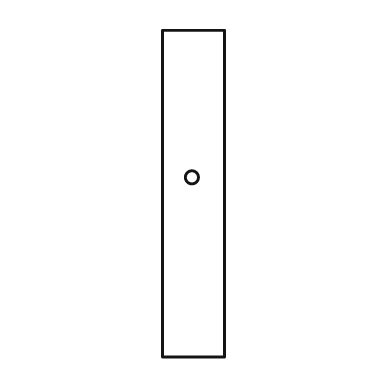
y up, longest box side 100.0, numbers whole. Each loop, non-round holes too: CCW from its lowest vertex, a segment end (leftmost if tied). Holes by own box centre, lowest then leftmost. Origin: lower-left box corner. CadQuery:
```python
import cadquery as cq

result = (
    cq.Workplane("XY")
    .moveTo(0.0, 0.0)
    .lineTo(19.0, 0.0)
    .lineTo(19.0, 100.0)
    .lineTo(0.0, 100.0)
    .close()
    .moveTo(9.0, 55.0)
    .circle(2.0)
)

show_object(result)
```